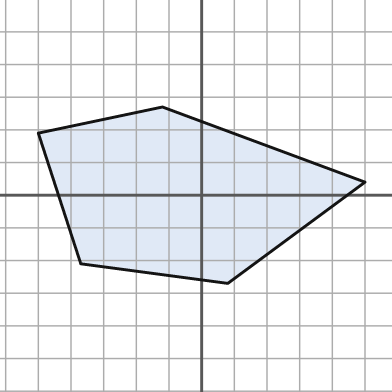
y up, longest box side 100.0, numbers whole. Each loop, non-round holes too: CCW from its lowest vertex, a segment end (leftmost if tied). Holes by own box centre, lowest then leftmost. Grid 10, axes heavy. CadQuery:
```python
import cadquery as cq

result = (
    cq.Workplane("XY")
    .moveTo(8.0, -27.0)
    .lineTo(50.0, 4.0)
    .lineTo(-12.0, 27.0)
    .lineTo(-50.0, 19.0)
    .lineTo(-37.0, -21.0)
    .close()
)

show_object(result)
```